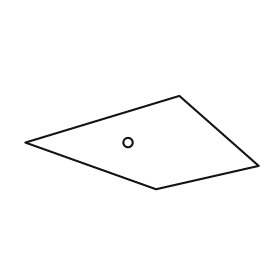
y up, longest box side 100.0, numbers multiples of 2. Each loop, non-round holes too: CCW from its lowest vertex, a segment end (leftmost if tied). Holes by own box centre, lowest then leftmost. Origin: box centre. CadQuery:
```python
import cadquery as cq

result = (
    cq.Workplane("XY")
    .moveTo(6.0, -20.0)
    .lineTo(50.0, -10.0)
    .lineTo(16.0, 20.0)
    .lineTo(-50.0, 0.0)
    .close()
    .moveTo(-6.0, 0.0)
    .circle(2.0)
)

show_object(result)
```